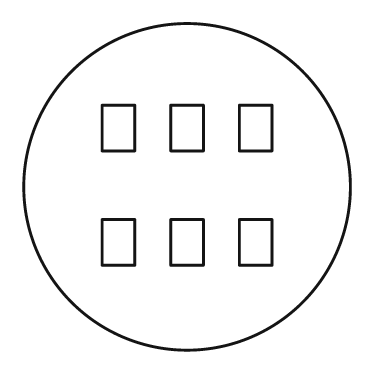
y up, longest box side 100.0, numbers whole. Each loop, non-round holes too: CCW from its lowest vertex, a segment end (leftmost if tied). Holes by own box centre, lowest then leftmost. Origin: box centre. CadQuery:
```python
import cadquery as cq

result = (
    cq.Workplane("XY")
    .moveTo(0.0, 0.0)
    .circle(50.0)
    .moveTo(-26.0, -24.0)
    .lineTo(-16.0, -24.0)
    .lineTo(-16.0, -10.0)
    .lineTo(-26.0, -10.0)
    .close()
    .moveTo(-5.0, -24.0)
    .lineTo(5.0, -24.0)
    .lineTo(5.0, -10.0)
    .lineTo(-5.0, -10.0)
    .close()
    .moveTo(16.0, -24.0)
    .lineTo(26.0, -24.0)
    .lineTo(26.0, -10.0)
    .lineTo(16.0, -10.0)
    .close()
    .moveTo(-26.0, 11.0)
    .lineTo(-16.0, 11.0)
    .lineTo(-16.0, 25.0)
    .lineTo(-26.0, 25.0)
    .close()
    .moveTo(-5.0, 11.0)
    .lineTo(5.0, 11.0)
    .lineTo(5.0, 25.0)
    .lineTo(-5.0, 25.0)
    .close()
    .moveTo(16.0, 11.0)
    .lineTo(26.0, 11.0)
    .lineTo(26.0, 25.0)
    .lineTo(16.0, 25.0)
    .close()
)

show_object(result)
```